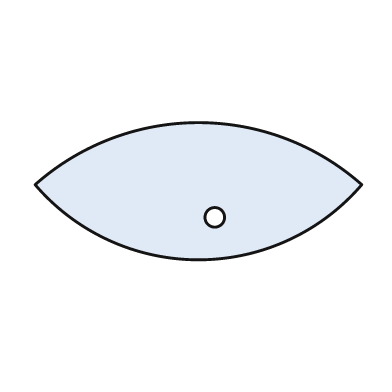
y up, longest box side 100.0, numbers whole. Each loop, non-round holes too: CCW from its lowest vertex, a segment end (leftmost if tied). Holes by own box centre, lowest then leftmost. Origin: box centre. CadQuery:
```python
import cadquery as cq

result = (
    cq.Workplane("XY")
    .moveTo(-50.0, 2.0)
    .threePointArc((0.0, -21.0), (50.0, 2.0))
    .threePointArc((0.0, 21.0), (-50.0, 2.0))
    .close()
    .moveTo(5.0, -8.0)
    .circle(3.0)
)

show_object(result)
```